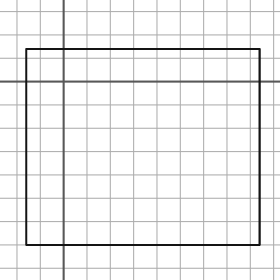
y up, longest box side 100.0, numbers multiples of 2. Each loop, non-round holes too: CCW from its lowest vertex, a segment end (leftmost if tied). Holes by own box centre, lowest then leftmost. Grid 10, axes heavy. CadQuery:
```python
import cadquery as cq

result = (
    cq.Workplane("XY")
    .moveTo(-16.0, -70.0)
    .lineTo(84.0, -70.0)
    .lineTo(84.0, 14.0)
    .lineTo(-16.0, 14.0)
    .close()
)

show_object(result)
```